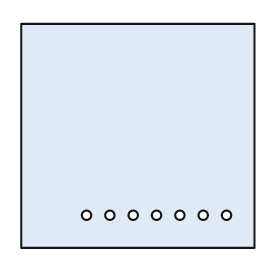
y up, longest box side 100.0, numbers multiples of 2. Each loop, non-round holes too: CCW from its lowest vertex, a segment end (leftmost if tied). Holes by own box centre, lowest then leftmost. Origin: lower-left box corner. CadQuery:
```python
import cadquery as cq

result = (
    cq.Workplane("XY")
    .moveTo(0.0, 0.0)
    .lineTo(100.0, 0.0)
    .lineTo(100.0, 96.0)
    .lineTo(0.0, 96.0)
    .close()
    .moveTo(28.0, 14.0)
    .circle(2.0)
    .moveTo(38.0, 14.0)
    .circle(2.0)
    .moveTo(48.0, 14.0)
    .circle(2.0)
    .moveTo(58.0, 14.0)
    .circle(2.0)
    .moveTo(68.0, 14.0)
    .circle(2.0)
    .moveTo(78.0, 14.0)
    .circle(2.0)
    .moveTo(88.0, 14.0)
    .circle(2.0)
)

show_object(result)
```